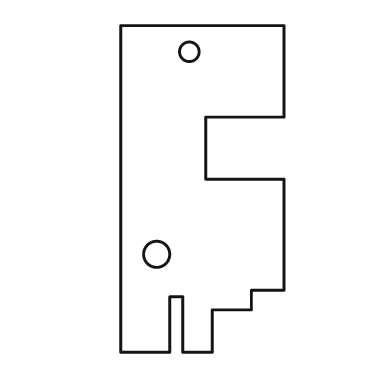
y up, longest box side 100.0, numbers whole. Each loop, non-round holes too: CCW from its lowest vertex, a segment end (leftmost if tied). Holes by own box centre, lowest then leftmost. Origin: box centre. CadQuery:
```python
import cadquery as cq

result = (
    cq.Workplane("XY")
    .moveTo(-25.0, -50.0)
    .lineTo(-10.0, -50.0)
    .lineTo(-10.0, -33.0)
    .lineTo(-6.0, -33.0)
    .lineTo(-6.0, -50.0)
    .lineTo(3.0, -50.0)
    .lineTo(3.0, -37.0)
    .lineTo(15.0, -37.0)
    .lineTo(15.0, -31.0)
    .lineTo(25.0, -31.0)
    .lineTo(25.0, 3.0)
    .lineTo(1.0, 3.0)
    .lineTo(1.0, 22.0)
    .lineTo(25.0, 22.0)
    .lineTo(25.0, 50.0)
    .lineTo(-25.0, 50.0)
    .close()
    .moveTo(-14.0, -20.0)
    .circle(4.0)
    .moveTo(-4.0, 42.0)
    .circle(3.0)
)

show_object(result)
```